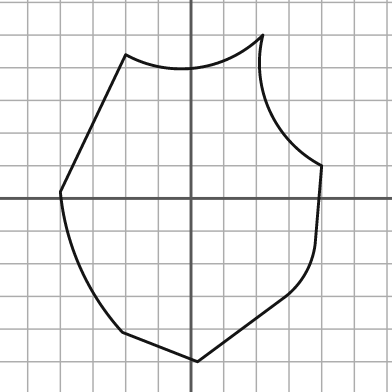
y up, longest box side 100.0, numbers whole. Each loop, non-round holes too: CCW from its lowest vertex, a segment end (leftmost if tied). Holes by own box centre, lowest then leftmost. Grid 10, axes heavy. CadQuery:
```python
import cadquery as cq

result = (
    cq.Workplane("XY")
    .moveTo(2.0, -50.0)
    .lineTo(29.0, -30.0)
    .threePointArc((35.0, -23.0), (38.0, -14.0))
    .lineTo(40.0, 10.0)
    .threePointArc((24.0, 27.0), (22.0, 50.0))
    .threePointArc((2.0, 40.0), (-20.0, 44.0))
    .lineTo(-40.0, 2.0)
    .threePointArc((-34.0, -21.0), (-21.0, -41.0))
    .close()
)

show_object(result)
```